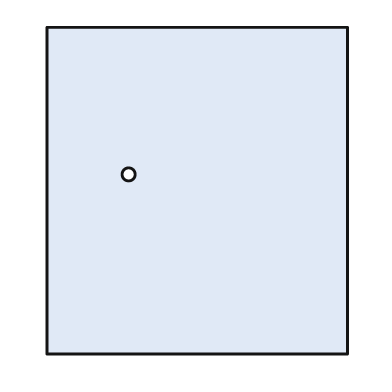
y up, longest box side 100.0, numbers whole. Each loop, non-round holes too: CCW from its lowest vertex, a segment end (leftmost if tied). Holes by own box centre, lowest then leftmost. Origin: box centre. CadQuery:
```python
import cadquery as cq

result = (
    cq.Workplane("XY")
    .moveTo(-46.0, -50.0)
    .lineTo(46.0, -50.0)
    .lineTo(46.0, 50.0)
    .lineTo(-46.0, 50.0)
    .close()
    .moveTo(-21.0, 5.0)
    .circle(2.0)
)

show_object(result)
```